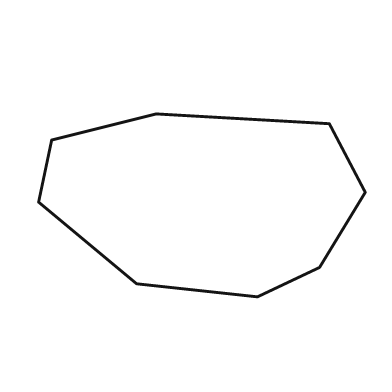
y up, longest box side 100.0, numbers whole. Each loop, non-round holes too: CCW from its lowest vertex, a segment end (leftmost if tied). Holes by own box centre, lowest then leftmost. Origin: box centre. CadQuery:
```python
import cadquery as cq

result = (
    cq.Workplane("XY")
    .moveTo(17.0, -28.0)
    .lineTo(36.0, -19.0)
    .lineTo(50.0, 4.0)
    .lineTo(39.0, 25.0)
    .lineTo(-14.0, 28.0)
    .lineTo(-46.0, 20.0)
    .lineTo(-50.0, 1.0)
    .lineTo(-20.0, -24.0)
    .close()
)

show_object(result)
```